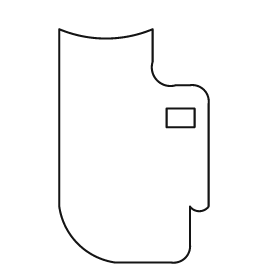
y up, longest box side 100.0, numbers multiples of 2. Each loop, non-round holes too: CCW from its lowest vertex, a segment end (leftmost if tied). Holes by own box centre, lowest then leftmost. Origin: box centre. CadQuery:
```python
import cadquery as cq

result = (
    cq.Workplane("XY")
    .moveTo(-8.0, -50.0)
    .lineTo(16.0, -50.0)
    .threePointArc((22.0, -48.0), (24.0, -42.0))
    .lineTo(24.0, -26.0)
    .threePointArc((28.0, -28.0), (32.0, -26.0))
    .lineTo(32.0, 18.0)
    .threePointArc((30.0, 24.0), (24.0, 26.0))
    .lineTo(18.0, 26.0)
    .threePointArc((10.0, 28.0), (8.0, 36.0))
    .lineTo(8.0, 50.0)
    .threePointArc((-12.0, 46.0), (-32.0, 50.0))
    .lineTo(-32.0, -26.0)
    .threePointArc((-24.0, -42.0), (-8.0, -50.0))
    .close()
    .moveTo(14.0, 8.0)
    .lineTo(26.0, 8.0)
    .lineTo(26.0, 16.0)
    .lineTo(14.0, 16.0)
    .close()
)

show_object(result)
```